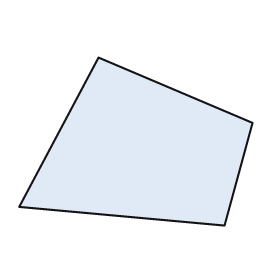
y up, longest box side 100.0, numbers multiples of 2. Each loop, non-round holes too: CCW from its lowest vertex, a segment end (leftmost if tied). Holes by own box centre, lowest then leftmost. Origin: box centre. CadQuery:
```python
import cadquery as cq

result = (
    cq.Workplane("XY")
    .moveTo(38.0, -36.0)
    .lineTo(50.0, 8.0)
    .lineTo(-16.0, 36.0)
    .lineTo(-50.0, -28.0)
    .close()
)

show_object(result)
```